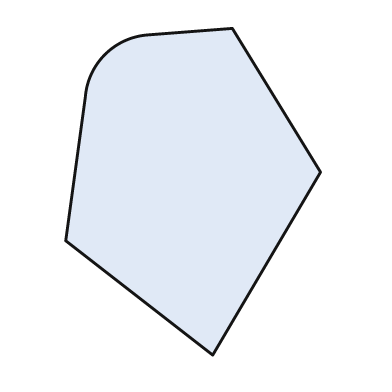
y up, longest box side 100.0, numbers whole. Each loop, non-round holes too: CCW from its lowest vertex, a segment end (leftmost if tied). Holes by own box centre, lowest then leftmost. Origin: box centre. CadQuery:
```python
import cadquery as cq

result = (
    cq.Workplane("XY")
    .moveTo(6.0, -50.0)
    .lineTo(39.0, 6.0)
    .lineTo(12.0, 50.0)
    .lineTo(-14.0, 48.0)
    .threePointArc((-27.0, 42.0), (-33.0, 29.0))
    .lineTo(-39.0, -15.0)
    .close()
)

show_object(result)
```